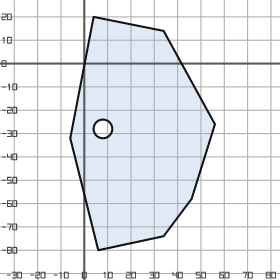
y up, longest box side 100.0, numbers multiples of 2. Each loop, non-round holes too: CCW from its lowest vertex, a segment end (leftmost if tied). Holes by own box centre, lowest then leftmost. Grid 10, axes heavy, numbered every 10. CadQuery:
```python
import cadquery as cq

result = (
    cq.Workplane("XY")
    .moveTo(6.0, -80.0)
    .lineTo(34.0, -74.0)
    .lineTo(46.0, -58.0)
    .lineTo(56.0, -26.0)
    .lineTo(34.0, 14.0)
    .lineTo(4.0, 20.0)
    .lineTo(-6.0, -32.0)
    .close()
    .moveTo(8.0, -28.0)
    .circle(4.0)
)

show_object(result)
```